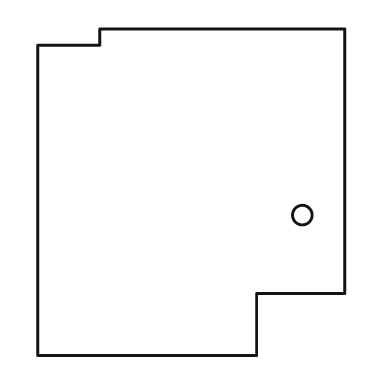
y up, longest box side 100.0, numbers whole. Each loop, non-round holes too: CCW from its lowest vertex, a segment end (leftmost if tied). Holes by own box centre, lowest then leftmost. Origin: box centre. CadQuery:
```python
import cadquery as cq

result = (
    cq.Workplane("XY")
    .moveTo(-47.0, -50.0)
    .lineTo(20.0, -50.0)
    .lineTo(20.0, -31.0)
    .lineTo(47.0, -31.0)
    .lineTo(47.0, 50.0)
    .lineTo(-28.0, 50.0)
    .lineTo(-28.0, 45.0)
    .lineTo(-47.0, 45.0)
    .close()
    .moveTo(34.0, -7.0)
    .circle(3.0)
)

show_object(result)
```